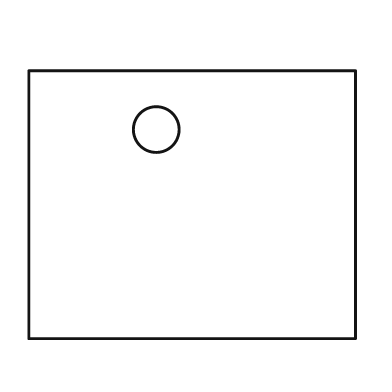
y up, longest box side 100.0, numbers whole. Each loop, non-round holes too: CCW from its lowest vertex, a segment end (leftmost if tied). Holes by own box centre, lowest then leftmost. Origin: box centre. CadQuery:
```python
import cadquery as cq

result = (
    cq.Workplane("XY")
    .moveTo(-50.0, -41.0)
    .lineTo(50.0, -41.0)
    .lineTo(50.0, 41.0)
    .lineTo(-50.0, 41.0)
    .close()
    .moveTo(-11.0, 23.0)
    .circle(7.0)
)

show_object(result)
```